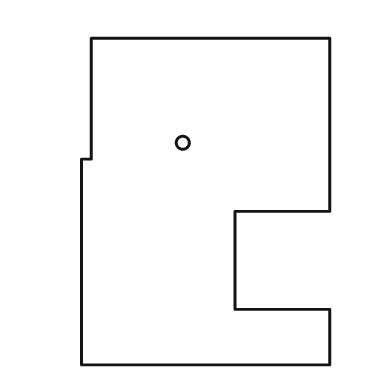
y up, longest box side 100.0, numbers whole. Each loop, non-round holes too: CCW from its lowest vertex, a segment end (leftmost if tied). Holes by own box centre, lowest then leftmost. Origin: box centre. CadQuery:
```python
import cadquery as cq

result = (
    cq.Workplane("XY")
    .moveTo(-38.0, -50.0)
    .lineTo(38.0, -50.0)
    .lineTo(38.0, -33.0)
    .lineTo(9.0, -33.0)
    .lineTo(9.0, -3.0)
    .lineTo(38.0, -3.0)
    .lineTo(38.0, 50.0)
    .lineTo(-35.0, 50.0)
    .lineTo(-35.0, 13.0)
    .lineTo(-38.0, 13.0)
    .close()
    .moveTo(-7.0, 18.0)
    .circle(2.0)
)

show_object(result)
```